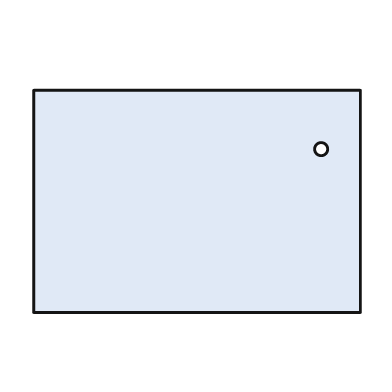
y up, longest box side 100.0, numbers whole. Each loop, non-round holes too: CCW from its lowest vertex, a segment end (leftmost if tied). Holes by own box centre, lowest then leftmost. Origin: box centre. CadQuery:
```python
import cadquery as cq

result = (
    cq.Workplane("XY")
    .moveTo(-50.0, -34.0)
    .lineTo(50.0, -34.0)
    .lineTo(50.0, 34.0)
    .lineTo(-50.0, 34.0)
    .close()
    .moveTo(38.0, 16.0)
    .circle(2.0)
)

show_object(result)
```